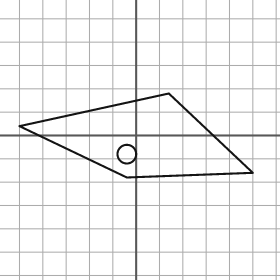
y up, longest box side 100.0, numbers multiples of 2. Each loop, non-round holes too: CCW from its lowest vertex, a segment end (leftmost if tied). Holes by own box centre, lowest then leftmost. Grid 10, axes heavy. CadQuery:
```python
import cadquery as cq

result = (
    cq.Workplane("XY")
    .moveTo(-4.0, -18.0)
    .lineTo(50.0, -16.0)
    .lineTo(14.0, 18.0)
    .lineTo(-50.0, 4.0)
    .close()
    .moveTo(-4.0, -8.0)
    .circle(4.0)
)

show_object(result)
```